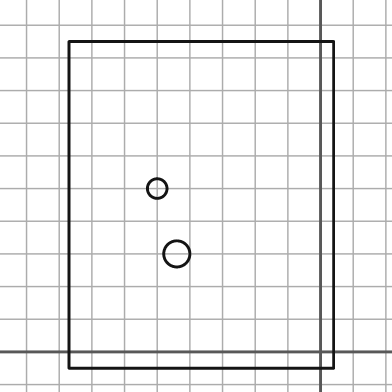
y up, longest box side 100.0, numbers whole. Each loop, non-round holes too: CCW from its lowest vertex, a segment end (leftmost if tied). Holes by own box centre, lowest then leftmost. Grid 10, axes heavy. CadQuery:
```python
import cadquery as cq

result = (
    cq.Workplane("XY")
    .moveTo(-77.0, -5.0)
    .lineTo(4.0, -5.0)
    .lineTo(4.0, 95.0)
    .lineTo(-77.0, 95.0)
    .close()
    .moveTo(-44.0, 30.0)
    .circle(4.0)
    .moveTo(-50.0, 50.0)
    .circle(3.0)
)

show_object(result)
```